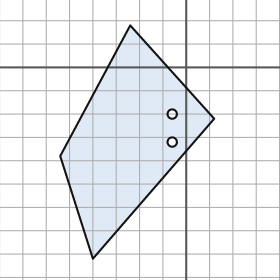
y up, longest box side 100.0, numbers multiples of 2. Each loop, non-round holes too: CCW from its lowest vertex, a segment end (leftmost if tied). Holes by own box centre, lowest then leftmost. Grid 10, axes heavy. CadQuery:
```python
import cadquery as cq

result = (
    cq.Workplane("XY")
    .moveTo(-40.0, -82.0)
    .lineTo(12.0, -22.0)
    .lineTo(-24.0, 18.0)
    .lineTo(-54.0, -38.0)
    .close()
    .moveTo(-6.0, -32.0)
    .circle(2.0)
    .moveTo(-6.0, -20.0)
    .circle(2.0)
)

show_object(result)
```